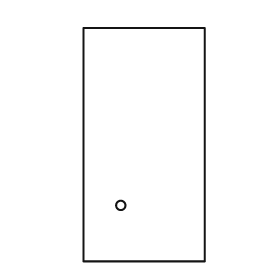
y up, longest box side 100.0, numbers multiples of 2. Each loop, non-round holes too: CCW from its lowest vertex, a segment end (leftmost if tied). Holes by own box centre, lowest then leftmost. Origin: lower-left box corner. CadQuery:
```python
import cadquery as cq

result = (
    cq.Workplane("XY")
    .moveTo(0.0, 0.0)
    .lineTo(52.0, 0.0)
    .lineTo(52.0, 100.0)
    .lineTo(0.0, 100.0)
    .close()
    .moveTo(16.0, 24.0)
    .circle(2.0)
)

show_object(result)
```